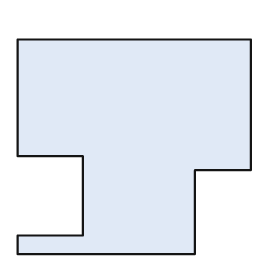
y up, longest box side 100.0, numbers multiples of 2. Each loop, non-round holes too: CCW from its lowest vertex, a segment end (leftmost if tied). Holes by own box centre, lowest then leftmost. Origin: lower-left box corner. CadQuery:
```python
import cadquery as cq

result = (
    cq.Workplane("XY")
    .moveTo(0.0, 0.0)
    .lineTo(76.0, 0.0)
    .lineTo(76.0, 36.0)
    .lineTo(100.0, 36.0)
    .lineTo(100.0, 92.0)
    .lineTo(0.0, 92.0)
    .lineTo(0.0, 42.0)
    .lineTo(28.0, 42.0)
    .lineTo(28.0, 8.0)
    .lineTo(0.0, 8.0)
    .close()
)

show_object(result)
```